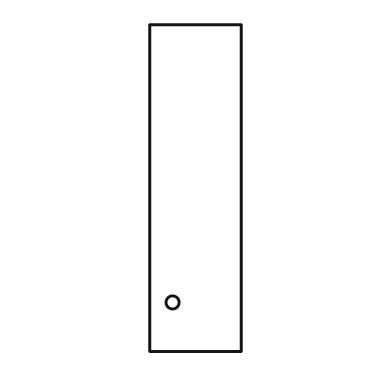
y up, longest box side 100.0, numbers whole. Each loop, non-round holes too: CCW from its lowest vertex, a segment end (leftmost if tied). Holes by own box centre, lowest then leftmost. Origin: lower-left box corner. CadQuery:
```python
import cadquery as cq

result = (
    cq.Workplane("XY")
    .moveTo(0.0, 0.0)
    .lineTo(28.0, 0.0)
    .lineTo(28.0, 100.0)
    .lineTo(0.0, 100.0)
    .close()
    .moveTo(7.0, 15.0)
    .circle(2.0)
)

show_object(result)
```